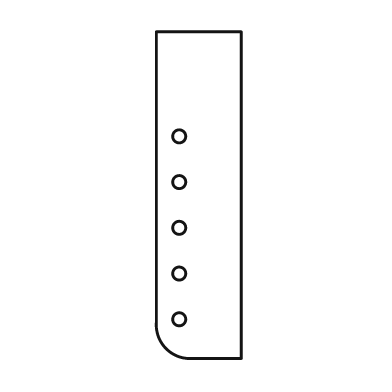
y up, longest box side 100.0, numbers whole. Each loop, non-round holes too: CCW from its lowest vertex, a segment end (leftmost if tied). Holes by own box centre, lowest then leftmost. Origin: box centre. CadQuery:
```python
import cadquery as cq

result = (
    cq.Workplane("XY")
    .moveTo(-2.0, -50.0)
    .lineTo(13.0, -50.0)
    .lineTo(13.0, 50.0)
    .lineTo(-13.0, 50.0)
    .lineTo(-13.0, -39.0)
    .threePointArc((-10.0, -47.0), (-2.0, -50.0))
    .close()
    .moveTo(-6.0, -38.0)
    .circle(2.0)
    .moveTo(-6.0, -24.0)
    .circle(2.0)
    .moveTo(-6.0, -10.0)
    .circle(2.0)
    .moveTo(-6.0, 4.0)
    .circle(2.0)
    .moveTo(-6.0, 18.0)
    .circle(2.0)
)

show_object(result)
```